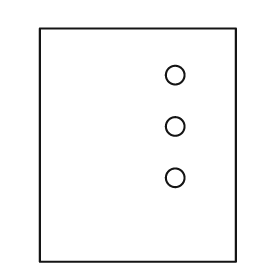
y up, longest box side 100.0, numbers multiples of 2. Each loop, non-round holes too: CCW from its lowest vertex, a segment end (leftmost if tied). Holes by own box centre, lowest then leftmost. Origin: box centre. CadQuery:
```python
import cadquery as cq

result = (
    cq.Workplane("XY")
    .moveTo(-42.0, -50.0)
    .lineTo(42.0, -50.0)
    .lineTo(42.0, 50.0)
    .lineTo(-42.0, 50.0)
    .close()
    .moveTo(16.0, -14.0)
    .circle(4.0)
    .moveTo(16.0, 8.0)
    .circle(4.0)
    .moveTo(16.0, 30.0)
    .circle(4.0)
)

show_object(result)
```